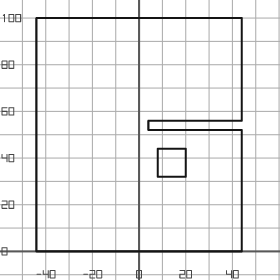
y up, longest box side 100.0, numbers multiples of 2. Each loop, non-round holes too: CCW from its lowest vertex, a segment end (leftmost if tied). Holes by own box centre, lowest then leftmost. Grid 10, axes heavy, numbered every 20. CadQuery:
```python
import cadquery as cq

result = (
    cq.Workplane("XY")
    .moveTo(-44.0, 0.0)
    .lineTo(44.0, 0.0)
    .lineTo(44.0, 52.0)
    .lineTo(4.0, 52.0)
    .lineTo(4.0, 56.0)
    .lineTo(44.0, 56.0)
    .lineTo(44.0, 100.0)
    .lineTo(-44.0, 100.0)
    .close()
    .moveTo(8.0, 32.0)
    .lineTo(20.0, 32.0)
    .lineTo(20.0, 44.0)
    .lineTo(8.0, 44.0)
    .close()
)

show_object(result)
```